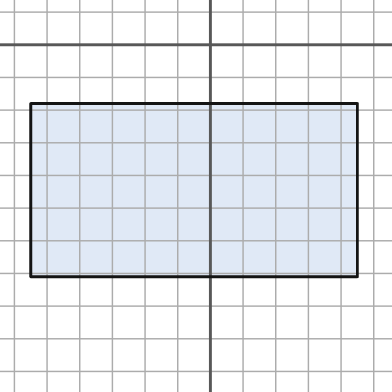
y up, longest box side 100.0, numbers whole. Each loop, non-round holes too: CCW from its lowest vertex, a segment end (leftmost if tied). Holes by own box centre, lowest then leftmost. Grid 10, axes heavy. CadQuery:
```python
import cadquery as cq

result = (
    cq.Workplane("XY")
    .moveTo(-55.0, -71.0)
    .lineTo(45.0, -71.0)
    .lineTo(45.0, -18.0)
    .lineTo(-55.0, -18.0)
    .close()
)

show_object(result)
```